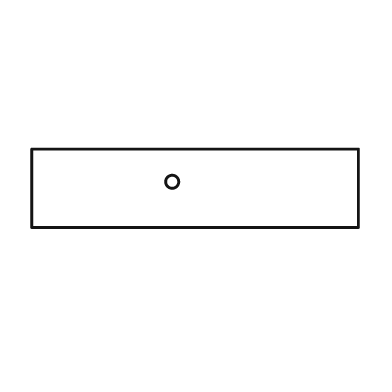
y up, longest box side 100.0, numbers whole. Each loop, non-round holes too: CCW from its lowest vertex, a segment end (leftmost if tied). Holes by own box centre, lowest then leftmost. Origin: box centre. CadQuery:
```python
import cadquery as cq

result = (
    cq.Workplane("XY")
    .moveTo(-50.0, -12.0)
    .lineTo(50.0, -12.0)
    .lineTo(50.0, 12.0)
    .lineTo(-50.0, 12.0)
    .close()
    .moveTo(-7.0, 2.0)
    .circle(2.0)
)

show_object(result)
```